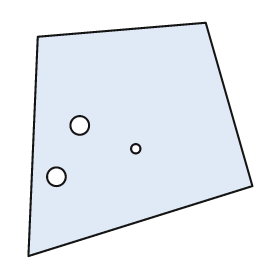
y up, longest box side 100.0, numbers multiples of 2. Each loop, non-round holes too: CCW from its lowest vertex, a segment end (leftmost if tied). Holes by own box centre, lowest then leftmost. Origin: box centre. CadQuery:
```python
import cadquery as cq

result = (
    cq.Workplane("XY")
    .moveTo(-48.0, -50.0)
    .lineTo(48.0, -20.0)
    .lineTo(28.0, 50.0)
    .lineTo(-44.0, 44.0)
    .close()
    .moveTo(-36.0, -16.0)
    .circle(4.0)
    .moveTo(-2.0, -4.0)
    .circle(2.0)
    .moveTo(-26.0, 6.0)
    .circle(4.0)
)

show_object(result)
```